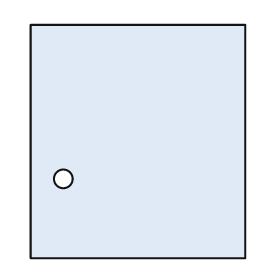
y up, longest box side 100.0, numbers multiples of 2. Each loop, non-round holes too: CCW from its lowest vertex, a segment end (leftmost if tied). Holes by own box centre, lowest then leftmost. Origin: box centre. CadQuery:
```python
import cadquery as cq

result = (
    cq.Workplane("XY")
    .moveTo(-46.0, -50.0)
    .lineTo(46.0, -50.0)
    .lineTo(46.0, 50.0)
    .lineTo(-46.0, 50.0)
    .close()
    .moveTo(-32.0, -16.0)
    .circle(4.0)
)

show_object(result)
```